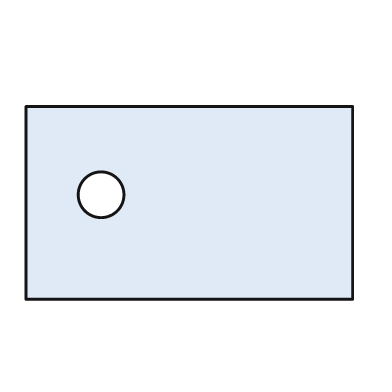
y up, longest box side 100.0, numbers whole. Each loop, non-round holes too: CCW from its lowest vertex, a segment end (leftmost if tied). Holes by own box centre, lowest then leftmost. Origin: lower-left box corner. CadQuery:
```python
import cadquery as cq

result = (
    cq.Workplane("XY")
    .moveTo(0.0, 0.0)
    .lineTo(100.0, 0.0)
    .lineTo(100.0, 59.0)
    .lineTo(0.0, 59.0)
    .close()
    .moveTo(23.0, 32.0)
    .circle(7.0)
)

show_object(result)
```